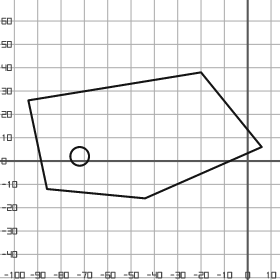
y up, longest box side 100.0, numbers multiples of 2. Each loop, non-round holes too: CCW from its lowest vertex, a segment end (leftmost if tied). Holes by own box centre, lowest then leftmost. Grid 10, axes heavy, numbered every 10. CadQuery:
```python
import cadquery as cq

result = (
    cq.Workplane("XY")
    .moveTo(-44.0, -16.0)
    .lineTo(6.0, 6.0)
    .lineTo(-20.0, 38.0)
    .lineTo(-94.0, 26.0)
    .lineTo(-86.0, -12.0)
    .close()
    .moveTo(-72.0, 2.0)
    .circle(4.0)
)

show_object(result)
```